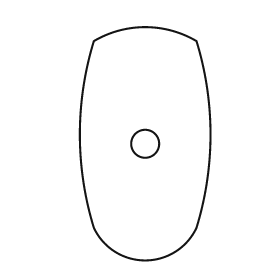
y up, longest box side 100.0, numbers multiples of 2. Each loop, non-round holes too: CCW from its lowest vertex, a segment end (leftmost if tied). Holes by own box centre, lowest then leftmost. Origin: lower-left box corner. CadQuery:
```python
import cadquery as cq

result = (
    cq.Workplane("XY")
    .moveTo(6.0, 14.0)
    .threePointArc((28.0, 0.0), (50.0, 14.0))
    .threePointArc((56.0, 54.0), (50.0, 94.0))
    .threePointArc((28.0, 100.0), (6.0, 94.0))
    .threePointArc((0.0, 54.0), (6.0, 14.0))
    .close()
    .moveTo(28.0, 50.0)
    .circle(6.0)
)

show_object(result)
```